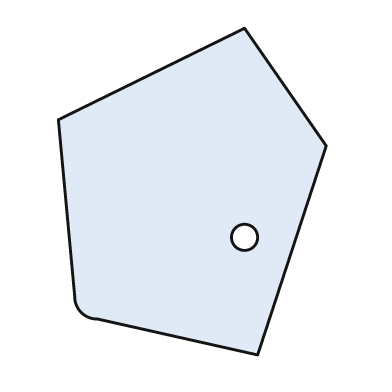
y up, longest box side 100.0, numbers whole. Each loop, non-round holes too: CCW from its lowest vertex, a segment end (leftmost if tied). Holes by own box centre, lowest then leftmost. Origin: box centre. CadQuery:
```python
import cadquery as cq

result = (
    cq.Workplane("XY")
    .moveTo(20.0, -50.0)
    .lineTo(41.0, 14.0)
    .lineTo(16.0, 50.0)
    .lineTo(-41.0, 22.0)
    .lineTo(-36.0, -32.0)
    .threePointArc((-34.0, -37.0), (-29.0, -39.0))
    .close()
    .moveTo(16.0, -14.0)
    .circle(4.0)
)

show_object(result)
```